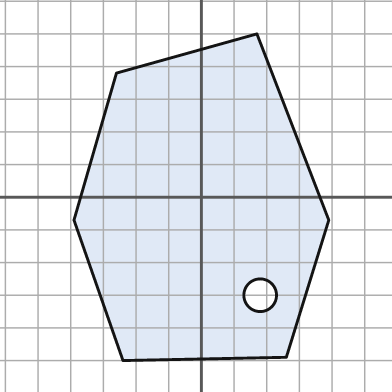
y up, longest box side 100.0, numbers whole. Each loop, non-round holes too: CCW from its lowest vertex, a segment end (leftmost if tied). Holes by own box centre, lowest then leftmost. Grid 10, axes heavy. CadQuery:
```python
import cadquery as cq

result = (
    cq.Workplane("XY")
    .moveTo(-24.0, -50.0)
    .lineTo(26.0, -49.0)
    .lineTo(39.0, -7.0)
    .lineTo(17.0, 50.0)
    .lineTo(-26.0, 38.0)
    .lineTo(-39.0, -7.0)
    .close()
    .moveTo(18.0, -30.0)
    .circle(5.0)
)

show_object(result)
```